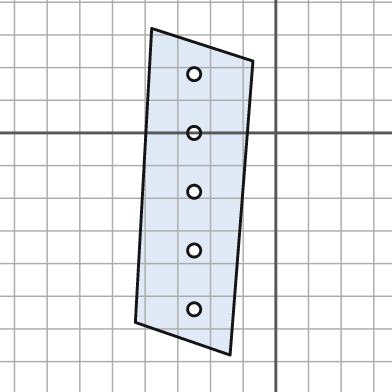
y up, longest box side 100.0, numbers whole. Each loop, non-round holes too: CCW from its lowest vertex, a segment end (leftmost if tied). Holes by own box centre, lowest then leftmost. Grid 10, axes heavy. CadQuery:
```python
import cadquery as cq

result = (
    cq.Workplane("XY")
    .moveTo(-14.0, -68.0)
    .lineTo(-7.0, 22.0)
    .lineTo(-38.0, 32.0)
    .lineTo(-43.0, -58.0)
    .close()
    .moveTo(-25.0, -54.0)
    .circle(2.0)
    .moveTo(-25.0, -36.0)
    .circle(2.0)
    .moveTo(-25.0, -18.0)
    .circle(2.0)
    .moveTo(-25.0, 0.0)
    .circle(2.0)
    .moveTo(-25.0, 18.0)
    .circle(2.0)
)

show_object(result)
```